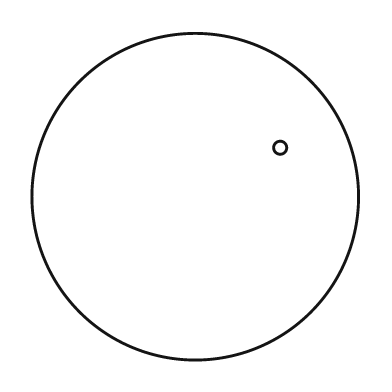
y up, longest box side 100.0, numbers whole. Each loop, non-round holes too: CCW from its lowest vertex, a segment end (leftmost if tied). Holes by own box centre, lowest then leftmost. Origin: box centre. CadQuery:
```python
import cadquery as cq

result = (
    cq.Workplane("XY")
    .moveTo(0.0, 0.0)
    .circle(50.0)
    .moveTo(26.0, 15.0)
    .circle(2.0)
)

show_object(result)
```